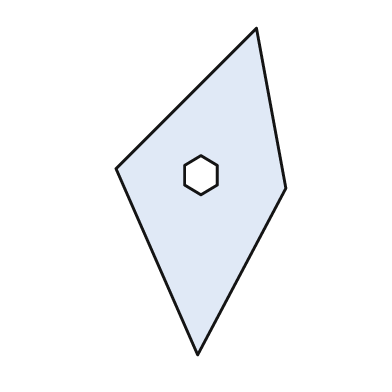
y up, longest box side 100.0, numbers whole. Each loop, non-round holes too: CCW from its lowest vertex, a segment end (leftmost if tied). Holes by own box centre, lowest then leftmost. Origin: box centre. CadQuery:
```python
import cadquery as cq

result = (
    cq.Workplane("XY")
    .moveTo(-1.0, -50.0)
    .lineTo(26.0, 1.0)
    .lineTo(17.0, 50.0)
    .lineTo(-26.0, 7.0)
    .close()
    .moveTo(0.0, -1.0)
    .lineTo(5.0, 2.0)
    .lineTo(5.0, 8.0)
    .lineTo(0.0, 11.0)
    .lineTo(-5.0, 8.0)
    .lineTo(-5.0, 2.0)
    .close()
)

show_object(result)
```